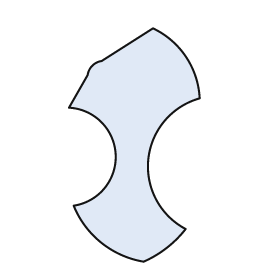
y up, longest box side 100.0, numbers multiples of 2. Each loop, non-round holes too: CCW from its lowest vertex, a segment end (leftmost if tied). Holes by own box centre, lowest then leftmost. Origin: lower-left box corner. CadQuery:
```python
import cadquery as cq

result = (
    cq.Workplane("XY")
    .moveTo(32.0, 0.0)
    .threePointArc((42.0, 6.0), (50.0, 14.0))
    .threePointArc((34.0, 44.0), (56.0, 70.0))
    .threePointArc((50.0, 88.0), (36.0, 100.0))
    .lineTo(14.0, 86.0)
    .threePointArc((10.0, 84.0), (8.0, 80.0))
    .lineTo(0.0, 66.0)
    .threePointArc((20.0, 46.0), (2.0, 24.0))
    .threePointArc((14.0, 8.0), (32.0, 0.0))
    .close()
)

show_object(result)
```